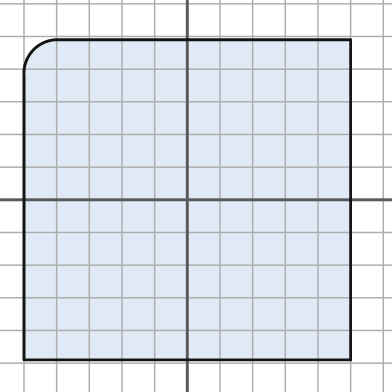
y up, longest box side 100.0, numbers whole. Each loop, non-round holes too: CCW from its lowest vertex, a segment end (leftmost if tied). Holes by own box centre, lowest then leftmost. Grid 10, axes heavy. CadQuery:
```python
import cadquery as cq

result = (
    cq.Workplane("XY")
    .moveTo(-50.0, -49.0)
    .lineTo(50.0, -49.0)
    .lineTo(50.0, 49.0)
    .lineTo(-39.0, 49.0)
    .threePointArc((-47.0, 46.0), (-50.0, 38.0))
    .close()
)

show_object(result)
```